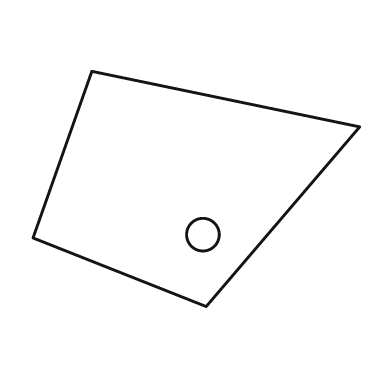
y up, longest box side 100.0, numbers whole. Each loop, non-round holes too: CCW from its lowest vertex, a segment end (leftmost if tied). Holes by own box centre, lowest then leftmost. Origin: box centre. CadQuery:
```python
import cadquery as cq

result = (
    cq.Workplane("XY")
    .moveTo(3.0, -36.0)
    .lineTo(50.0, 19.0)
    .lineTo(-32.0, 36.0)
    .lineTo(-50.0, -15.0)
    .close()
    .moveTo(2.0, -14.0)
    .circle(5.0)
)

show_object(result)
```